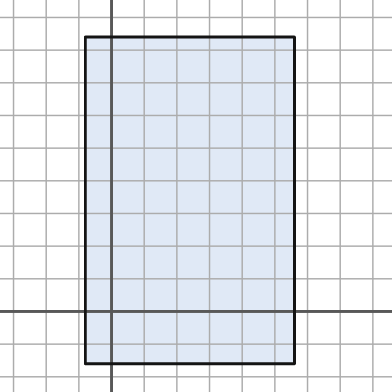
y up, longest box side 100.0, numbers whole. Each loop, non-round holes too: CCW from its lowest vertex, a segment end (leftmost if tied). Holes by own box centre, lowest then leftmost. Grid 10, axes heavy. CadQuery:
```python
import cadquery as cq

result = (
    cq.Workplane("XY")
    .moveTo(-8.0, -16.0)
    .lineTo(56.0, -16.0)
    .lineTo(56.0, 84.0)
    .lineTo(-8.0, 84.0)
    .close()
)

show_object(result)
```